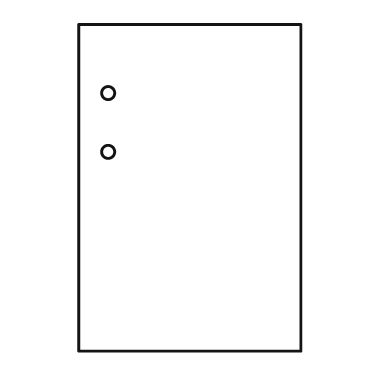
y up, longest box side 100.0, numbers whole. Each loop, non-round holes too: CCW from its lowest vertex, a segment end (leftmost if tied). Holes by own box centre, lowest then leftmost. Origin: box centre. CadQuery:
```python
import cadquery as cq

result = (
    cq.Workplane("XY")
    .moveTo(-34.0, -50.0)
    .lineTo(34.0, -50.0)
    .lineTo(34.0, 50.0)
    .lineTo(-34.0, 50.0)
    .close()
    .moveTo(-25.0, 11.0)
    .circle(2.0)
    .moveTo(-25.0, 29.0)
    .circle(2.0)
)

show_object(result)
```